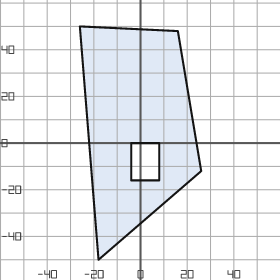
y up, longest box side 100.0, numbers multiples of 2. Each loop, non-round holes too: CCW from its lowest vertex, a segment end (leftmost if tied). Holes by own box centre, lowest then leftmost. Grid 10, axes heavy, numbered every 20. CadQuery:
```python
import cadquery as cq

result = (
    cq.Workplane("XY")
    .moveTo(-18.0, -50.0)
    .lineTo(26.0, -12.0)
    .lineTo(16.0, 48.0)
    .lineTo(-26.0, 50.0)
    .close()
    .moveTo(-4.0, -16.0)
    .lineTo(8.0, -16.0)
    .lineTo(8.0, 0.0)
    .lineTo(-4.0, 0.0)
    .close()
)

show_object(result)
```